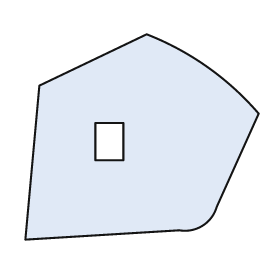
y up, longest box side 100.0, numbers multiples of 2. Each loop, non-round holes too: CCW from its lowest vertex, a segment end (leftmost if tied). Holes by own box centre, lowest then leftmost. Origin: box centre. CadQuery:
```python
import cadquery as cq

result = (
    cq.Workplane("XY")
    .moveTo(-50.0, -44.0)
    .lineTo(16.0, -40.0)
    .threePointArc((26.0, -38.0), (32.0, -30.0))
    .lineTo(50.0, 10.0)
    .threePointArc((28.0, 30.0), (2.0, 44.0))
    .lineTo(-44.0, 22.0)
    .close()
    .moveTo(-20.0, -10.0)
    .lineTo(-8.0, -10.0)
    .lineTo(-8.0, 6.0)
    .lineTo(-20.0, 6.0)
    .close()
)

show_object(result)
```